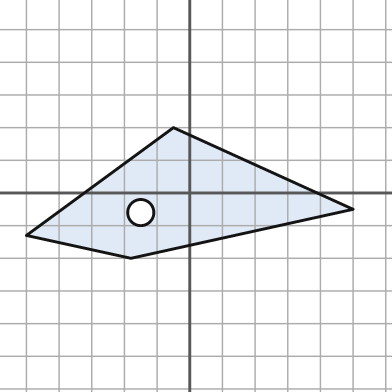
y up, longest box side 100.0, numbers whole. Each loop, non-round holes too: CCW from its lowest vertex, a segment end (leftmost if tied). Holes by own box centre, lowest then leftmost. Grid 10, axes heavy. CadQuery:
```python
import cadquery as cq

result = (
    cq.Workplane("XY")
    .moveTo(-18.0, -20.0)
    .lineTo(50.0, -5.0)
    .lineTo(-5.0, 20.0)
    .lineTo(-50.0, -13.0)
    .close()
    .moveTo(-15.0, -6.0)
    .circle(4.0)
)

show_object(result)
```